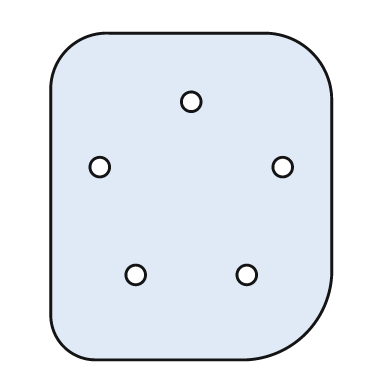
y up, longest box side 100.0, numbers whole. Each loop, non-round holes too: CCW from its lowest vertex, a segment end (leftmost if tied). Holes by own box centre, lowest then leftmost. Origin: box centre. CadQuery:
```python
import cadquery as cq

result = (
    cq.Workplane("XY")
    .moveTo(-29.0, -50.0)
    .lineTo(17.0, -50.0)
    .threePointArc((35.0, -42.0), (43.0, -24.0))
    .lineTo(43.0, 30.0)
    .threePointArc((37.0, 44.0), (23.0, 50.0))
    .lineTo(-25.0, 50.0)
    .threePointArc((-38.0, 45.0), (-43.0, 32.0))
    .lineTo(-43.0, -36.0)
    .threePointArc((-39.0, -46.0), (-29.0, -50.0))
    .close()
    .moveTo(-17.0, -24.0)
    .circle(3.0)
    .moveTo(17.0, -24.0)
    .circle(3.0)
    .moveTo(-28.0, 9.0)
    .circle(3.0)
    .moveTo(28.0, 9.0)
    .circle(3.0)
    .moveTo(0.0, 29.0)
    .circle(3.0)
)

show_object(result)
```